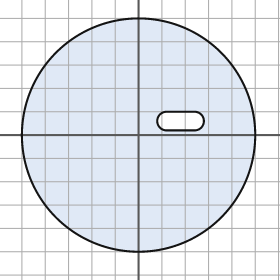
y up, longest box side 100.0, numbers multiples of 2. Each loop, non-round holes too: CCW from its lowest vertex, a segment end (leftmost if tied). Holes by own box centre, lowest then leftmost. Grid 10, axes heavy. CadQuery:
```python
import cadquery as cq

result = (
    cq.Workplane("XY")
    .moveTo(0.0, 0.0)
    .circle(50.0)
    .moveTo(12.0, 2.0)
    .lineTo(24.0, 2.0)
    .threePointArc((28.0, 6.0), (24.0, 10.0))
    .lineTo(12.0, 10.0)
    .threePointArc((8.0, 6.0), (12.0, 2.0))
    .close()
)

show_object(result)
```